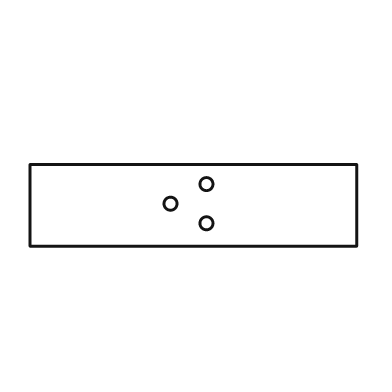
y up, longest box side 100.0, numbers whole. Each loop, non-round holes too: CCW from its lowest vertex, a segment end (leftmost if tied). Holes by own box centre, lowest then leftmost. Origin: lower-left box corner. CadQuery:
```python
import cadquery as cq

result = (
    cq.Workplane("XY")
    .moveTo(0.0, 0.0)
    .lineTo(100.0, 0.0)
    .lineTo(100.0, 25.0)
    .lineTo(0.0, 25.0)
    .close()
    .moveTo(54.0, 7.0)
    .circle(2.0)
    .moveTo(43.0, 13.0)
    .circle(2.0)
    .moveTo(54.0, 19.0)
    .circle(2.0)
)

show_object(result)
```